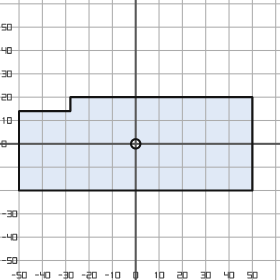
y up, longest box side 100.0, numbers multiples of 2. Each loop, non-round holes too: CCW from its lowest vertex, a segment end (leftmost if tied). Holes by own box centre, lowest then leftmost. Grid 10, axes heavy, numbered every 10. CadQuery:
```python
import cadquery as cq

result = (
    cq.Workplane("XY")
    .moveTo(-50.0, -20.0)
    .lineTo(50.0, -20.0)
    .lineTo(50.0, 20.0)
    .lineTo(-28.0, 20.0)
    .lineTo(-28.0, 14.0)
    .lineTo(-50.0, 14.0)
    .close()
    .moveTo(0.0, 0.0)
    .circle(2.0)
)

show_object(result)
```